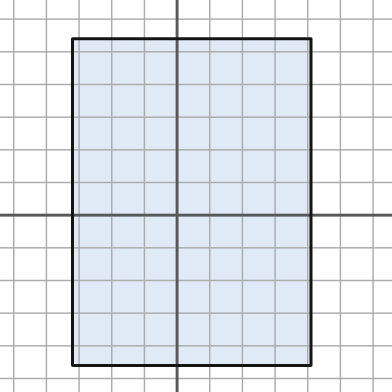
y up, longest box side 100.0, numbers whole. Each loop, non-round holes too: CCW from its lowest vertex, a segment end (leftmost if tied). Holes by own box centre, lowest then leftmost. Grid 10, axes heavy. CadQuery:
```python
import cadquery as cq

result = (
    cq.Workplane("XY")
    .moveTo(-32.0, -46.0)
    .lineTo(41.0, -46.0)
    .lineTo(41.0, 54.0)
    .lineTo(-32.0, 54.0)
    .close()
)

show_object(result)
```